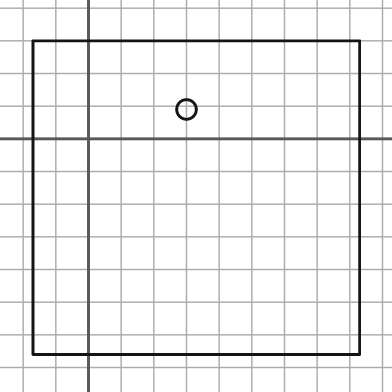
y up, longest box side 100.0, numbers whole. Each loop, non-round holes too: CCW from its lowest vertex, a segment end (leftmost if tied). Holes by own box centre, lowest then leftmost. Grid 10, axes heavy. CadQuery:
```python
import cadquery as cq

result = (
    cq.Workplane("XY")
    .moveTo(-17.0, -66.0)
    .lineTo(83.0, -66.0)
    .lineTo(83.0, 30.0)
    .lineTo(-17.0, 30.0)
    .close()
    .moveTo(30.0, 9.0)
    .circle(3.0)
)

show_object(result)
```